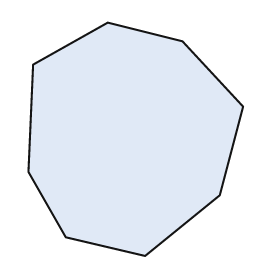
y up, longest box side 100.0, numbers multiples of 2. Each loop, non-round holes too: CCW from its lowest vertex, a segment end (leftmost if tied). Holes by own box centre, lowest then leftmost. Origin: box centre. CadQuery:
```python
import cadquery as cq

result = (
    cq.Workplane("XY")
    .moveTo(4.0, -50.0)
    .lineTo(36.0, -24.0)
    .lineTo(46.0, 14.0)
    .lineTo(20.0, 42.0)
    .lineTo(-12.0, 50.0)
    .lineTo(-44.0, 32.0)
    .lineTo(-46.0, -14.0)
    .lineTo(-30.0, -42.0)
    .close()
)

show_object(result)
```